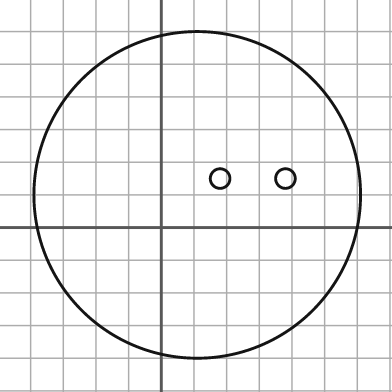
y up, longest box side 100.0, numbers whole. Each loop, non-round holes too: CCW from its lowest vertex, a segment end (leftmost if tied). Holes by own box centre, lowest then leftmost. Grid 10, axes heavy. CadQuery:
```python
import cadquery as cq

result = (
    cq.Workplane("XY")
    .moveTo(11.0, 10.0)
    .circle(50.0)
    .moveTo(18.0, 15.0)
    .circle(3.0)
    .moveTo(38.0, 15.0)
    .circle(3.0)
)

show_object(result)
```